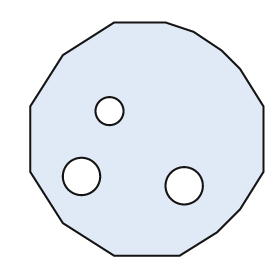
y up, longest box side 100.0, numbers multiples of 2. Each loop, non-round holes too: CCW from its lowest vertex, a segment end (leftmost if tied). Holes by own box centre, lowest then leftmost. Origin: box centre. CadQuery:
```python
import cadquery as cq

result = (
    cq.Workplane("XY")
    .moveTo(-14.0, -50.0)
    .lineTo(14.0, -50.0)
    .lineTo(30.0, -40.0)
    .lineTo(40.0, -30.0)
    .lineTo(50.0, -14.0)
    .lineTo(50.0, 14.0)
    .lineTo(40.0, 30.0)
    .lineTo(32.0, 38.0)
    .lineTo(20.0, 46.0)
    .lineTo(8.0, 50.0)
    .lineTo(-14.0, 50.0)
    .lineTo(-36.0, 36.0)
    .lineTo(-50.0, 14.0)
    .lineTo(-50.0, -14.0)
    .lineTo(-36.0, -36.0)
    .close()
    .moveTo(16.0, -20.0)
    .circle(8.0)
    .moveTo(-28.0, -16.0)
    .circle(8.0)
    .moveTo(-16.0, 12.0)
    .circle(6.0)
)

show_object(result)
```